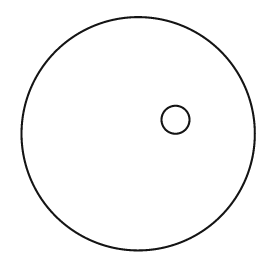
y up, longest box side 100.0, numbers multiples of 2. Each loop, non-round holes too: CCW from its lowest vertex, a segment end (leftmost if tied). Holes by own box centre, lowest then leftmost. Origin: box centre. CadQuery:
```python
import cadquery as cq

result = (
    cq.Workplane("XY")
    .moveTo(0.0, 0.0)
    .circle(50.0)
    .moveTo(16.0, 6.0)
    .circle(6.0)
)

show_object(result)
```